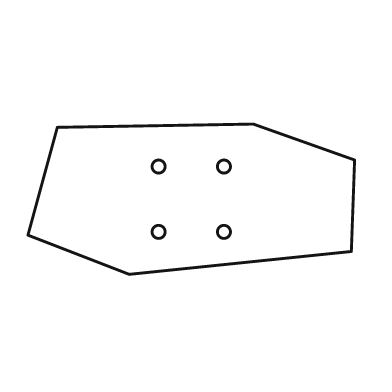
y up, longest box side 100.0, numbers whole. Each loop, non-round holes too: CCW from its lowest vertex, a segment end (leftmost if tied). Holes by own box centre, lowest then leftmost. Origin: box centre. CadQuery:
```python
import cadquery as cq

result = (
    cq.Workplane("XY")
    .moveTo(-19.0, -23.0)
    .lineTo(49.0, -16.0)
    .lineTo(50.0, 12.0)
    .lineTo(19.0, 23.0)
    .lineTo(-41.0, 22.0)
    .lineTo(-50.0, -11.0)
    .close()
    .moveTo(-10.0, -10.0)
    .circle(2.0)
    .moveTo(10.0, -10.0)
    .circle(2.0)
    .moveTo(-10.0, 10.0)
    .circle(2.0)
    .moveTo(10.0, 10.0)
    .circle(2.0)
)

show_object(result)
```